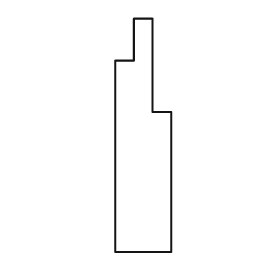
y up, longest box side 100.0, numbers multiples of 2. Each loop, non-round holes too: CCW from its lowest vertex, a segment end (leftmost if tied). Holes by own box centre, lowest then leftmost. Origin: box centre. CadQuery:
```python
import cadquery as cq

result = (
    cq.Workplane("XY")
    .moveTo(-12.0, -50.0)
    .lineTo(12.0, -50.0)
    .lineTo(12.0, 10.0)
    .lineTo(4.0, 10.0)
    .lineTo(4.0, 50.0)
    .lineTo(-4.0, 50.0)
    .lineTo(-4.0, 32.0)
    .lineTo(-12.0, 32.0)
    .close()
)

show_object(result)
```